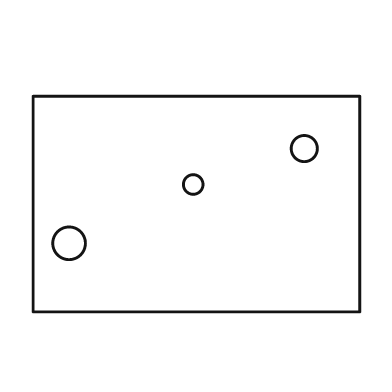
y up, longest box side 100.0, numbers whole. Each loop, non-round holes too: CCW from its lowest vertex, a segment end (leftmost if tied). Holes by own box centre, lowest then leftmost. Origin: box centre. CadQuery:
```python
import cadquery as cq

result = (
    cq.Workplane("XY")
    .moveTo(-50.0, -33.0)
    .lineTo(50.0, -33.0)
    .lineTo(50.0, 33.0)
    .lineTo(-50.0, 33.0)
    .close()
    .moveTo(-39.0, -12.0)
    .circle(5.0)
    .moveTo(-1.0, 6.0)
    .circle(3.0)
    .moveTo(33.0, 17.0)
    .circle(4.0)
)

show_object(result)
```